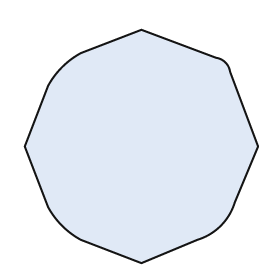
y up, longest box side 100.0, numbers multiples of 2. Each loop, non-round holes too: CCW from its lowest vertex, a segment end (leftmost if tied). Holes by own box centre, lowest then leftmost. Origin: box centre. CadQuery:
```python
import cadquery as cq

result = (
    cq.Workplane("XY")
    .moveTo(0.0, -50.0)
    .lineTo(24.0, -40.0)
    .threePointArc((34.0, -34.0), (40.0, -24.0))
    .lineTo(50.0, 0.0)
    .lineTo(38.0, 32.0)
    .threePointArc((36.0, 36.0), (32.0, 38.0))
    .lineTo(0.0, 50.0)
    .lineTo(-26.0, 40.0)
    .threePointArc((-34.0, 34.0), (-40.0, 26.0))
    .lineTo(-50.0, 0.0)
    .lineTo(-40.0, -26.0)
    .threePointArc((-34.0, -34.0), (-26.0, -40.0))
    .close()
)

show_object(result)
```